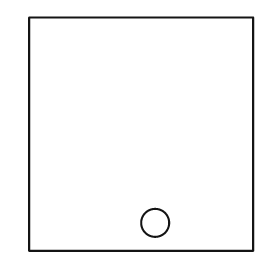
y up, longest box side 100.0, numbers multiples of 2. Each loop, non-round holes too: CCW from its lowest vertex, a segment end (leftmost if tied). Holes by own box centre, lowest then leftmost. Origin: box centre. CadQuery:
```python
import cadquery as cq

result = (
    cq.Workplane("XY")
    .moveTo(-48.0, -50.0)
    .lineTo(48.0, -50.0)
    .lineTo(48.0, 50.0)
    .lineTo(-48.0, 50.0)
    .close()
    .moveTo(6.0, -38.0)
    .circle(6.0)
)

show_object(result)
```